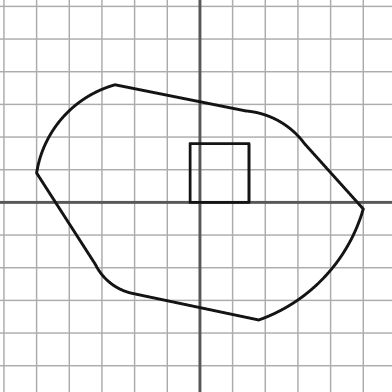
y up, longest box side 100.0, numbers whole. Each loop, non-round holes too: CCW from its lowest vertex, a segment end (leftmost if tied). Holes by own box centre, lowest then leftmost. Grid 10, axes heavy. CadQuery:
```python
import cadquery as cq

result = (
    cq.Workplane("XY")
    .moveTo(18.0, -36.0)
    .threePointArc((38.0, -23.0), (50.0, -2.0))
    .lineTo(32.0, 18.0)
    .threePointArc((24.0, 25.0), (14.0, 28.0))
    .lineTo(-26.0, 36.0)
    .threePointArc((-42.0, 26.0), (-50.0, 9.0))
    .lineTo(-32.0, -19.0)
    .threePointArc((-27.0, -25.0), (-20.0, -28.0))
    .close()
    .moveTo(-3.0, 0.0)
    .lineTo(15.0, 0.0)
    .lineTo(15.0, 18.0)
    .lineTo(-3.0, 18.0)
    .close()
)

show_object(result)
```